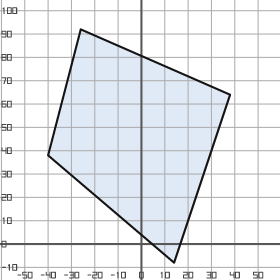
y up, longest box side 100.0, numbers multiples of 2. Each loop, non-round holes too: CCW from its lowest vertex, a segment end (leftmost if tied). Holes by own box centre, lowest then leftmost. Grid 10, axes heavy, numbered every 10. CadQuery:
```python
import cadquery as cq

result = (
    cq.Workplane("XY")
    .moveTo(14.0, -8.0)
    .lineTo(38.0, 64.0)
    .lineTo(-26.0, 92.0)
    .lineTo(-40.0, 38.0)
    .close()
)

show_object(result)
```